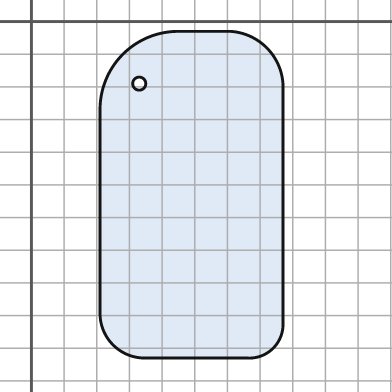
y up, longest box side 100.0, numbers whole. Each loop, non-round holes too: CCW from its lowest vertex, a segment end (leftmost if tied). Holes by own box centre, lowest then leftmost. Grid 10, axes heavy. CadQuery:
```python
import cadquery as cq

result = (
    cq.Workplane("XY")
    .moveTo(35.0, -103.0)
    .lineTo(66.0, -103.0)
    .threePointArc((74.0, -100.0), (77.0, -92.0))
    .lineTo(77.0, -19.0)
    .threePointArc((72.0, -8.0), (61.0, -3.0))
    .lineTo(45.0, -3.0)
    .threePointArc((28.0, -10.0), (21.0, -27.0))
    .lineTo(21.0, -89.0)
    .threePointArc((25.0, -99.0), (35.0, -103.0))
    .close()
    .moveTo(33.0, -19.0)
    .circle(2.0)
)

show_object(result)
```